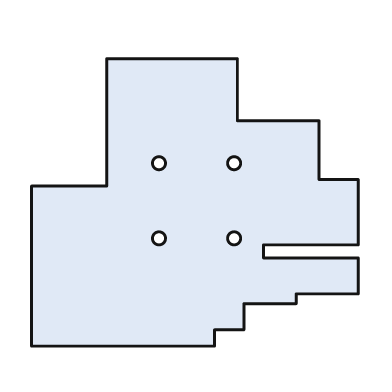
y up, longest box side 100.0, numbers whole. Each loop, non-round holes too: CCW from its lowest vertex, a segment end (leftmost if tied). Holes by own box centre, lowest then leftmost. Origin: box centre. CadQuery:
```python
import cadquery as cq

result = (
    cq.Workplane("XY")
    .moveTo(-50.0, -44.0)
    .lineTo(6.0, -44.0)
    .lineTo(6.0, -39.0)
    .lineTo(15.0, -39.0)
    .lineTo(15.0, -31.0)
    .lineTo(31.0, -31.0)
    .lineTo(31.0, -28.0)
    .lineTo(50.0, -28.0)
    .lineTo(50.0, -17.0)
    .lineTo(21.0, -17.0)
    .lineTo(21.0, -13.0)
    .lineTo(50.0, -13.0)
    .lineTo(50.0, 7.0)
    .lineTo(38.0, 7.0)
    .lineTo(38.0, 25.0)
    .lineTo(13.0, 25.0)
    .lineTo(13.0, 44.0)
    .lineTo(-27.0, 44.0)
    .lineTo(-27.0, 5.0)
    .lineTo(-50.0, 5.0)
    .close()
    .moveTo(-11.0, -11.0)
    .circle(2.0)
    .moveTo(12.0, -11.0)
    .circle(2.0)
    .moveTo(-11.0, 12.0)
    .circle(2.0)
    .moveTo(12.0, 12.0)
    .circle(2.0)
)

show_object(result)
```